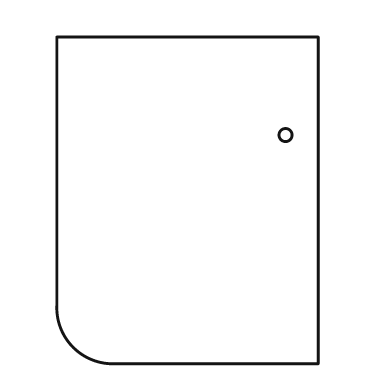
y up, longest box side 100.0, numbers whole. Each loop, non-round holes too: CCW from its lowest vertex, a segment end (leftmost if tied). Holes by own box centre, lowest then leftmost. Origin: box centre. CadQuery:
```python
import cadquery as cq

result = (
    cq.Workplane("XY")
    .moveTo(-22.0, -50.0)
    .lineTo(40.0, -50.0)
    .lineTo(40.0, 50.0)
    .lineTo(-40.0, 50.0)
    .lineTo(-40.0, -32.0)
    .threePointArc((-35.0, -45.0), (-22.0, -50.0))
    .close()
    .moveTo(30.0, 20.0)
    .circle(2.0)
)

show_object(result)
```